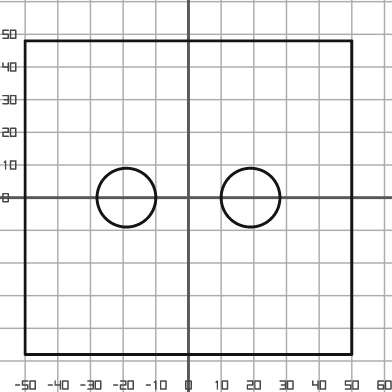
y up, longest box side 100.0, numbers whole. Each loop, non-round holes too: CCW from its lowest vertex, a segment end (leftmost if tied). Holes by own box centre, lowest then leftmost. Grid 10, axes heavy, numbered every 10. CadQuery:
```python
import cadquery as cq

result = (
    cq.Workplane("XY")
    .moveTo(-50.0, -48.0)
    .lineTo(50.0, -48.0)
    .lineTo(50.0, 48.0)
    .lineTo(-50.0, 48.0)
    .close()
    .moveTo(-19.0, 0.0)
    .circle(9.0)
    .moveTo(19.0, 0.0)
    .circle(9.0)
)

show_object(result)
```